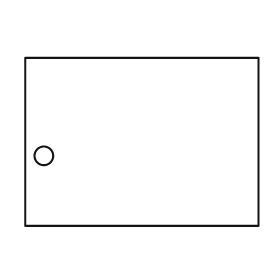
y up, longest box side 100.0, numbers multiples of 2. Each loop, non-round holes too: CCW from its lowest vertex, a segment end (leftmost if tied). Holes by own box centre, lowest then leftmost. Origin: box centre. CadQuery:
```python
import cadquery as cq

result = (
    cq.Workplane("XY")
    .moveTo(-50.0, -36.0)
    .lineTo(50.0, -36.0)
    .lineTo(50.0, 36.0)
    .lineTo(-50.0, 36.0)
    .close()
    .moveTo(-42.0, -6.0)
    .circle(4.0)
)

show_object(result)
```